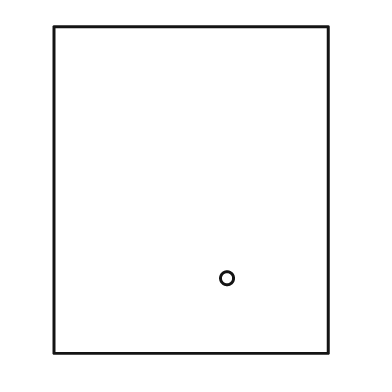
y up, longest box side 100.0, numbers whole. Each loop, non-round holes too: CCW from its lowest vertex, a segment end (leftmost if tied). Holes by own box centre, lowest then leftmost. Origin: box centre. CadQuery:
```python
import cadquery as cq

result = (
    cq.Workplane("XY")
    .moveTo(-42.0, -50.0)
    .lineTo(42.0, -50.0)
    .lineTo(42.0, 50.0)
    .lineTo(-42.0, 50.0)
    .close()
    .moveTo(11.0, -27.0)
    .circle(2.0)
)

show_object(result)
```